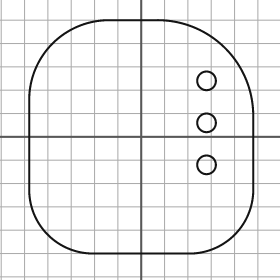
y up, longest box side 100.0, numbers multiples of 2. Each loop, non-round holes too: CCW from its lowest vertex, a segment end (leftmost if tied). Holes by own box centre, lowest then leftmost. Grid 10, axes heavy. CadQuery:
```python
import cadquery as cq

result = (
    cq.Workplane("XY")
    .moveTo(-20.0, -50.0)
    .lineTo(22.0, -50.0)
    .threePointArc((40.0, -42.0), (48.0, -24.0))
    .lineTo(48.0, 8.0)
    .threePointArc((36.0, 38.0), (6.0, 50.0))
    .lineTo(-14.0, 50.0)
    .threePointArc((-38.0, 40.0), (-48.0, 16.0))
    .lineTo(-48.0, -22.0)
    .threePointArc((-40.0, -42.0), (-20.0, -50.0))
    .close()
    .moveTo(28.0, -12.0)
    .circle(4.0)
    .moveTo(28.0, 6.0)
    .circle(4.0)
    .moveTo(28.0, 24.0)
    .circle(4.0)
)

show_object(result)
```